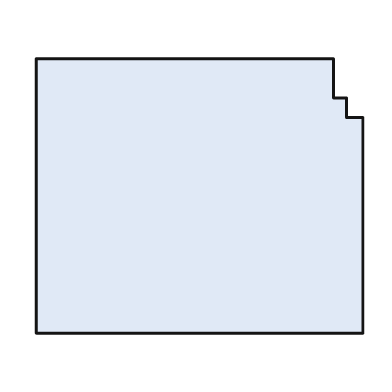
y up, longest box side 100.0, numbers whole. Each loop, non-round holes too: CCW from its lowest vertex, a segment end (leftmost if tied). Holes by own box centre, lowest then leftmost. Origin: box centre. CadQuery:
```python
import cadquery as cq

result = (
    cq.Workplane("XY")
    .moveTo(-50.0, -42.0)
    .lineTo(50.0, -42.0)
    .lineTo(50.0, 24.0)
    .lineTo(45.0, 24.0)
    .lineTo(45.0, 30.0)
    .lineTo(41.0, 30.0)
    .lineTo(41.0, 42.0)
    .lineTo(-50.0, 42.0)
    .close()
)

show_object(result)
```